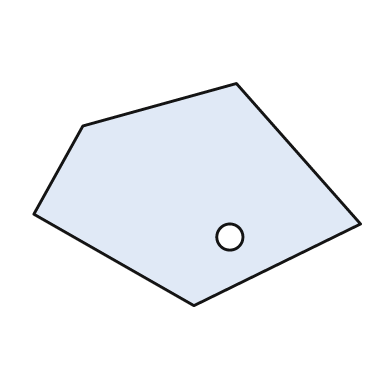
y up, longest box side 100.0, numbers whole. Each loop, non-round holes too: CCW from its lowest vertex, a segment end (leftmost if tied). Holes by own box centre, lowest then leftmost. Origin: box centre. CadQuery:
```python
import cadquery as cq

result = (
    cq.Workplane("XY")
    .moveTo(-1.0, -34.0)
    .lineTo(50.0, -9.0)
    .lineTo(12.0, 34.0)
    .lineTo(-35.0, 21.0)
    .lineTo(-50.0, -6.0)
    .close()
    .moveTo(10.0, -13.0)
    .circle(4.0)
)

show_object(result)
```